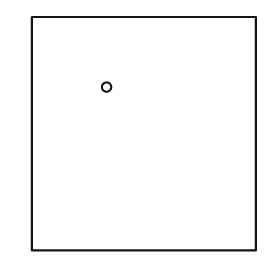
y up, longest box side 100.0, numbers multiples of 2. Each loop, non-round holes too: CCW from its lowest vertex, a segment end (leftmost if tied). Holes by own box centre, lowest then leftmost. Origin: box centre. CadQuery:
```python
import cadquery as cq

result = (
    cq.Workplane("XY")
    .moveTo(-48.0, -50.0)
    .lineTo(48.0, -50.0)
    .lineTo(48.0, 50.0)
    .lineTo(-48.0, 50.0)
    .close()
    .moveTo(-16.0, 20.0)
    .circle(2.0)
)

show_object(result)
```